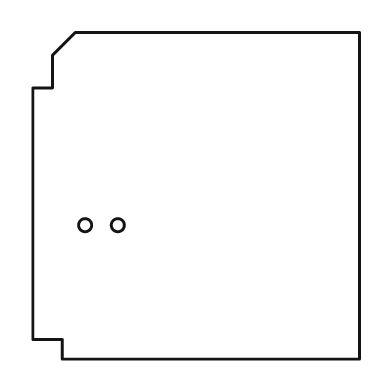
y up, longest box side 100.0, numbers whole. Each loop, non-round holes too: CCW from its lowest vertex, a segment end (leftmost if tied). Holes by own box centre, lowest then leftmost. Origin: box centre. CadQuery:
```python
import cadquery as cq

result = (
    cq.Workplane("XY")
    .moveTo(-41.0, -50.0)
    .lineTo(50.0, -50.0)
    .lineTo(50.0, 50.0)
    .lineTo(-37.0, 50.0)
    .lineTo(-44.0, 43.0)
    .lineTo(-44.0, 33.0)
    .lineTo(-50.0, 33.0)
    .lineTo(-50.0, -44.0)
    .lineTo(-41.0, -44.0)
    .close()
    .moveTo(-34.0, -9.0)
    .circle(2.0)
    .moveTo(-24.0, -9.0)
    .circle(2.0)
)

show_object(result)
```